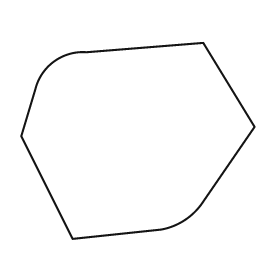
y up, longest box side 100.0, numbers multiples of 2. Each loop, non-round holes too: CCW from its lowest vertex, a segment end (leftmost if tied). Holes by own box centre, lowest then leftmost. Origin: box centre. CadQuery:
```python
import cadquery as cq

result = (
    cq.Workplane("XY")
    .moveTo(-28.0, -42.0)
    .lineTo(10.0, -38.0)
    .threePointArc((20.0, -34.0), (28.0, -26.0))
    .lineTo(50.0, 6.0)
    .lineTo(28.0, 42.0)
    .lineTo(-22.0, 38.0)
    .threePointArc((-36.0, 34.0), (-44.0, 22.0))
    .lineTo(-50.0, 2.0)
    .close()
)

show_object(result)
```